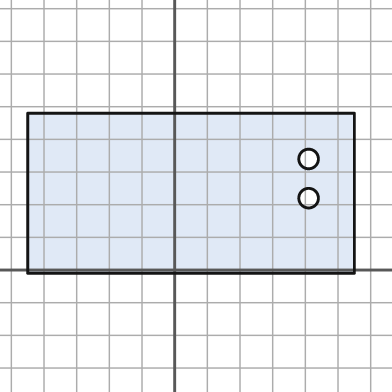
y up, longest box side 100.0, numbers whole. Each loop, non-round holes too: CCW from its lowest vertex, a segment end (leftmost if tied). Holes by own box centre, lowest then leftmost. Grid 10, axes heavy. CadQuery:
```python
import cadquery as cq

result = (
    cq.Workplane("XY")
    .moveTo(-45.0, -1.0)
    .lineTo(55.0, -1.0)
    .lineTo(55.0, 48.0)
    .lineTo(-45.0, 48.0)
    .close()
    .moveTo(41.0, 22.0)
    .circle(3.0)
    .moveTo(41.0, 34.0)
    .circle(3.0)
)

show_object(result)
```